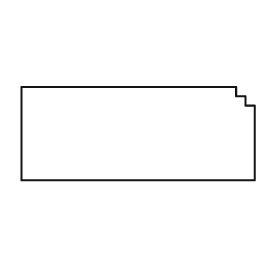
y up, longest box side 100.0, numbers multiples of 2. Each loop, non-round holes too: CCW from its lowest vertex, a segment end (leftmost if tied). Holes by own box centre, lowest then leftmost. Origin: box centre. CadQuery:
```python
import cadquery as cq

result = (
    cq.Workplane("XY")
    .moveTo(-50.0, -20.0)
    .lineTo(50.0, -20.0)
    .lineTo(50.0, 12.0)
    .lineTo(46.0, 12.0)
    .lineTo(46.0, 16.0)
    .lineTo(42.0, 16.0)
    .lineTo(42.0, 20.0)
    .lineTo(-50.0, 20.0)
    .close()
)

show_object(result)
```